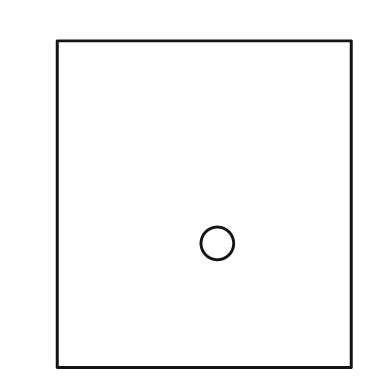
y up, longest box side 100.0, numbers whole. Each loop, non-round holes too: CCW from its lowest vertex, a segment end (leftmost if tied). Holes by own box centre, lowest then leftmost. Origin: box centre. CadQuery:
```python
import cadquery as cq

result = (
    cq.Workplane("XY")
    .moveTo(-45.0, -50.0)
    .lineTo(45.0, -50.0)
    .lineTo(45.0, 50.0)
    .lineTo(-45.0, 50.0)
    .close()
    .moveTo(4.0, -12.0)
    .circle(5.0)
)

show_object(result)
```